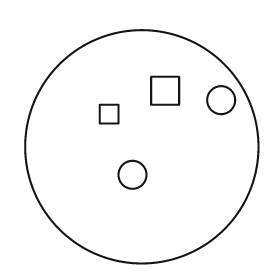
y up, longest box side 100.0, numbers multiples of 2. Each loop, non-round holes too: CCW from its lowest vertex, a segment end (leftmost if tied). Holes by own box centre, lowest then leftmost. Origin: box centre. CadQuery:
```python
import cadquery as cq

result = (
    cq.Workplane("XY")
    .moveTo(0.0, 0.0)
    .circle(50.0)
    .moveTo(-4.0, -12.0)
    .circle(6.0)
    .moveTo(-18.0, 10.0)
    .lineTo(-10.0, 10.0)
    .lineTo(-10.0, 18.0)
    .lineTo(-18.0, 18.0)
    .close()
    .moveTo(34.0, 20.0)
    .circle(6.0)
    .moveTo(4.0, 18.0)
    .lineTo(16.0, 18.0)
    .lineTo(16.0, 30.0)
    .lineTo(4.0, 30.0)
    .close()
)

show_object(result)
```